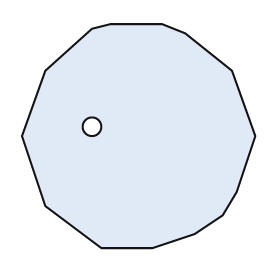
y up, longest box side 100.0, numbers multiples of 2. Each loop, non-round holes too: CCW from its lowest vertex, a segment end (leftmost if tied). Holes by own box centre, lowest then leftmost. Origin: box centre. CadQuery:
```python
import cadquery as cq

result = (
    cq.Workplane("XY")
    .moveTo(-16.0, -48.0)
    .lineTo(6.0, -48.0)
    .lineTo(24.0, -42.0)
    .lineTo(36.0, -34.0)
    .lineTo(42.0, -24.0)
    .lineTo(50.0, 0.0)
    .lineTo(40.0, 28.0)
    .lineTo(20.0, 44.0)
    .lineTo(10.0, 48.0)
    .lineTo(-12.0, 48.0)
    .lineTo(-20.0, 46.0)
    .lineTo(-40.0, 28.0)
    .lineTo(-50.0, 0.0)
    .lineTo(-40.0, -30.0)
    .close()
    .moveTo(-20.0, 4.0)
    .circle(4.0)
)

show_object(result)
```